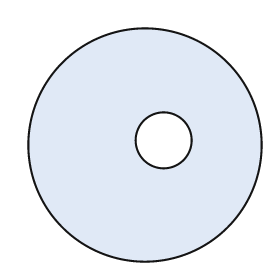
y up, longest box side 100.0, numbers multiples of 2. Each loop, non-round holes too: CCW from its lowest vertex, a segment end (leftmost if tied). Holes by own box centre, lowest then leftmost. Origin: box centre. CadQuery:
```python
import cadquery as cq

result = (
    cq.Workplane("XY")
    .moveTo(0.0, 0.0)
    .circle(50.0)
    .moveTo(8.0, 2.0)
    .circle(12.0)
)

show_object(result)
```